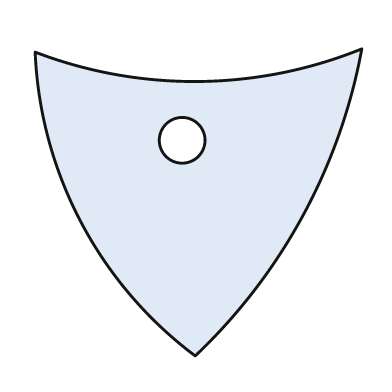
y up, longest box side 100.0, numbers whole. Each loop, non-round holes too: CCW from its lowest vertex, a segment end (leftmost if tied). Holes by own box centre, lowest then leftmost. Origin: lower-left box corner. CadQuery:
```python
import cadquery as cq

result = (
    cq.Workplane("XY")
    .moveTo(49.0, 0.0)
    .threePointArc((82.0, 43.0), (100.0, 94.0))
    .threePointArc((50.0, 84.0), (0.0, 93.0))
    .threePointArc((14.0, 41.0), (49.0, 0.0))
    .close()
    .moveTo(45.0, 66.0)
    .circle(7.0)
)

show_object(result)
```